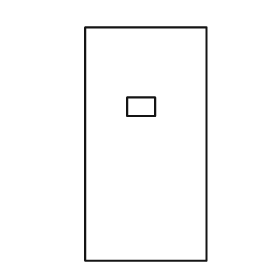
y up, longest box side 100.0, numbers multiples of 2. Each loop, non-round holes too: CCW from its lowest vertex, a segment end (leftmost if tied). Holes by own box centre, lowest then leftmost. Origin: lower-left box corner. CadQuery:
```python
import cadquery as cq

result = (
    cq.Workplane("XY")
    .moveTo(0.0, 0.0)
    .lineTo(52.0, 0.0)
    .lineTo(52.0, 100.0)
    .lineTo(0.0, 100.0)
    .close()
    .moveTo(18.0, 62.0)
    .lineTo(30.0, 62.0)
    .lineTo(30.0, 70.0)
    .lineTo(18.0, 70.0)
    .close()
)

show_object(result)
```